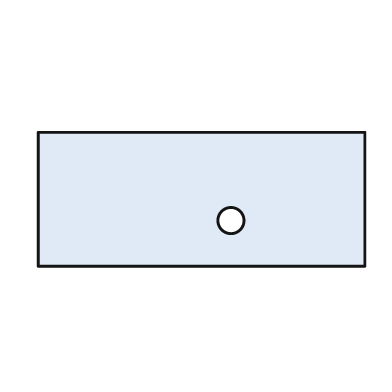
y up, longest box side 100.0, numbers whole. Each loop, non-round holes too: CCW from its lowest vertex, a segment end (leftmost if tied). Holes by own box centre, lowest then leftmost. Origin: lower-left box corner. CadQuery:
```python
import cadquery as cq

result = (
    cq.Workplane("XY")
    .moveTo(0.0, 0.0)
    .lineTo(100.0, 0.0)
    .lineTo(100.0, 41.0)
    .lineTo(0.0, 41.0)
    .close()
    .moveTo(59.0, 14.0)
    .circle(4.0)
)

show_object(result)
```